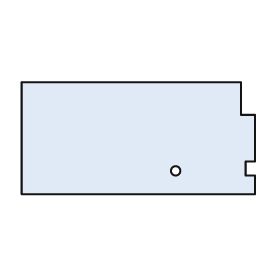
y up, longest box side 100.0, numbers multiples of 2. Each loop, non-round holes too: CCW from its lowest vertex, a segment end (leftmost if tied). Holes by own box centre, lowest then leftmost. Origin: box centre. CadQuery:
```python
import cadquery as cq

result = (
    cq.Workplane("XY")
    .moveTo(-50.0, -24.0)
    .lineTo(50.0, -24.0)
    .lineTo(50.0, -16.0)
    .lineTo(46.0, -16.0)
    .lineTo(46.0, -10.0)
    .lineTo(50.0, -10.0)
    .lineTo(50.0, 10.0)
    .lineTo(44.0, 10.0)
    .lineTo(44.0, 24.0)
    .lineTo(-50.0, 24.0)
    .close()
    .moveTo(16.0, -14.0)
    .circle(2.0)
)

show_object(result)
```